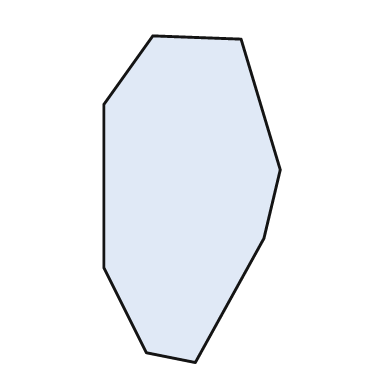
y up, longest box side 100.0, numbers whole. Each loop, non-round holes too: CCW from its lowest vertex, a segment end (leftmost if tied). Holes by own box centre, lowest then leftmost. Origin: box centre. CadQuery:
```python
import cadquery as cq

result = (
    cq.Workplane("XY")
    .moveTo(1.0, -50.0)
    .lineTo(22.0, -12.0)
    .lineTo(27.0, 9.0)
    .lineTo(15.0, 49.0)
    .lineTo(-12.0, 50.0)
    .lineTo(-27.0, 29.0)
    .lineTo(-27.0, -21.0)
    .lineTo(-14.0, -47.0)
    .close()
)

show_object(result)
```